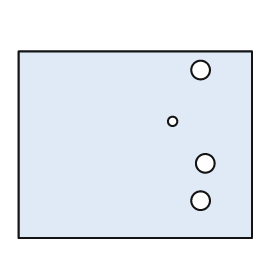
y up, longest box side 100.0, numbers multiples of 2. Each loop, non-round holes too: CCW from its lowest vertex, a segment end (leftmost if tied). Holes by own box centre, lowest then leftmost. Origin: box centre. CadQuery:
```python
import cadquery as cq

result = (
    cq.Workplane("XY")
    .moveTo(-50.0, -40.0)
    .lineTo(50.0, -40.0)
    .lineTo(50.0, 40.0)
    .lineTo(-50.0, 40.0)
    .close()
    .moveTo(28.0, -24.0)
    .circle(4.0)
    .moveTo(30.0, -8.0)
    .circle(4.0)
    .moveTo(16.0, 10.0)
    .circle(2.0)
    .moveTo(28.0, 32.0)
    .circle(4.0)
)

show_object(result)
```